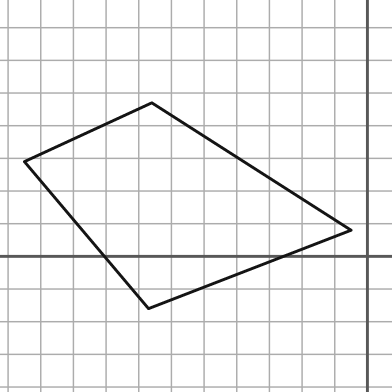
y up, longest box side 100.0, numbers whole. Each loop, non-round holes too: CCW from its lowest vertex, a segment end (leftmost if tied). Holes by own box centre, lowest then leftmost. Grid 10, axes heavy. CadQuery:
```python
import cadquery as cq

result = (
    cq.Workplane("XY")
    .moveTo(-67.0, -16.0)
    .lineTo(-5.0, 8.0)
    .lineTo(-66.0, 47.0)
    .lineTo(-105.0, 29.0)
    .close()
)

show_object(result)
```